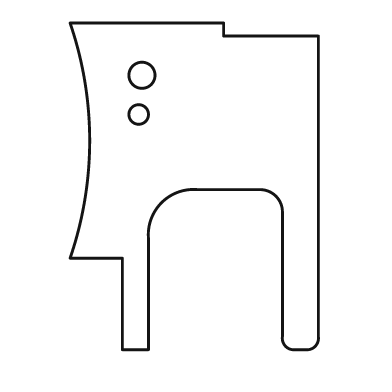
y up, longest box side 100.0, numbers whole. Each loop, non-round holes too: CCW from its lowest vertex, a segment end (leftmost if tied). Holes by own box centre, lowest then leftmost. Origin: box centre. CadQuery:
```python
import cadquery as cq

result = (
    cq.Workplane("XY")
    .moveTo(-22.0, -50.0)
    .lineTo(-14.0, -50.0)
    .lineTo(-14.0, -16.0)
    .threePointArc((-10.0, -5.0), (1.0, -1.0))
    .lineTo(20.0, -1.0)
    .threePointArc((25.0, -3.0), (27.0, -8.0))
    .lineTo(27.0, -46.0)
    .threePointArc((28.0, -49.0), (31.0, -50.0))
    .lineTo(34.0, -50.0)
    .threePointArc((37.0, -49.0), (38.0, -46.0))
    .lineTo(38.0, 46.0)
    .lineTo(9.0, 46.0)
    .lineTo(9.0, 50.0)
    .lineTo(-38.0, 50.0)
    .threePointArc((-32.0, 14.0), (-38.0, -22.0))
    .lineTo(-22.0, -22.0)
    .close()
    .moveTo(-17.0, 22.0)
    .circle(3.0)
    .moveTo(-16.0, 34.0)
    .circle(4.0)
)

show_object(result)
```